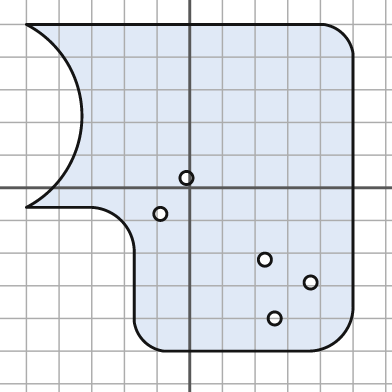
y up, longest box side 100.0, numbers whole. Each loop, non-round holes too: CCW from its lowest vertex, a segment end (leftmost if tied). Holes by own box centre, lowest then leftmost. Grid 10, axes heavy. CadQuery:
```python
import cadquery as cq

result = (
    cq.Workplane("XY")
    .moveTo(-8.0, -50.0)
    .lineTo(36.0, -50.0)
    .threePointArc((46.0, -46.0), (50.0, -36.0))
    .lineTo(50.0, 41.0)
    .threePointArc((47.0, 47.0), (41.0, 50.0))
    .lineTo(-50.0, 50.0)
    .threePointArc((-33.0, 22.0), (-50.0, -6.0))
    .lineTo(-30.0, -6.0)
    .threePointArc((-21.0, -10.0), (-17.0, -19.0))
    .lineTo(-17.0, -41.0)
    .threePointArc((-14.0, -47.0), (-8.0, -50.0))
    .close()
    .moveTo(26.0, -40.0)
    .circle(2.0)
    .moveTo(37.0, -29.0)
    .circle(2.0)
    .moveTo(23.0, -22.0)
    .circle(2.0)
    .moveTo(-9.0, -8.0)
    .circle(2.0)
    .moveTo(-1.0, 3.0)
    .circle(2.0)
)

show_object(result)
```